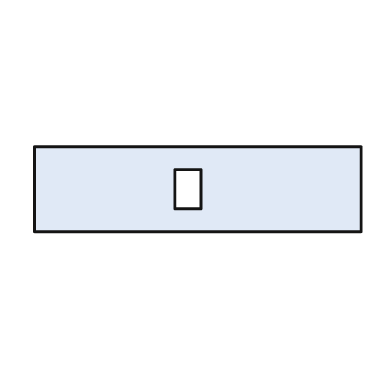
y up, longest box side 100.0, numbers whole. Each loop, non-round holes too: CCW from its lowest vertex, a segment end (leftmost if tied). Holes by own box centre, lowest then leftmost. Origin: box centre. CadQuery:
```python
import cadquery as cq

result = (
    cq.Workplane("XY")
    .moveTo(-50.0, -13.0)
    .lineTo(50.0, -13.0)
    .lineTo(50.0, 13.0)
    .lineTo(-50.0, 13.0)
    .close()
    .moveTo(-7.0, -6.0)
    .lineTo(1.0, -6.0)
    .lineTo(1.0, 6.0)
    .lineTo(-7.0, 6.0)
    .close()
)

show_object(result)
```